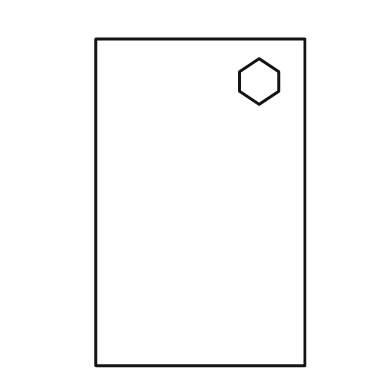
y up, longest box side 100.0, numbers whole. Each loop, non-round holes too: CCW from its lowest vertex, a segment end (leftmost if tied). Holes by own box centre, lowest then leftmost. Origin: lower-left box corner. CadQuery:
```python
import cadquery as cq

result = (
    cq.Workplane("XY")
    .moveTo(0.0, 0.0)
    .lineTo(64.0, 0.0)
    .lineTo(64.0, 100.0)
    .lineTo(0.0, 100.0)
    .close()
    .moveTo(50.0, 80.0)
    .lineTo(56.0, 84.0)
    .lineTo(56.0, 90.0)
    .lineTo(50.0, 94.0)
    .lineTo(44.0, 90.0)
    .lineTo(44.0, 84.0)
    .close()
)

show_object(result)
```